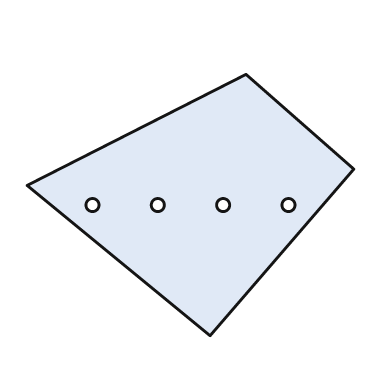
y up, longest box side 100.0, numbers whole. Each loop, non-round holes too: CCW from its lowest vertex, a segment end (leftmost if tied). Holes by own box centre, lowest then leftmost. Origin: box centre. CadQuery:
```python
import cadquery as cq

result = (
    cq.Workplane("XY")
    .moveTo(6.0, -40.0)
    .lineTo(50.0, 11.0)
    .lineTo(17.0, 40.0)
    .lineTo(-50.0, 6.0)
    .close()
    .moveTo(-30.0, 0.0)
    .circle(2.0)
    .moveTo(-10.0, 0.0)
    .circle(2.0)
    .moveTo(10.0, 0.0)
    .circle(2.0)
    .moveTo(30.0, 0.0)
    .circle(2.0)
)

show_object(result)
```